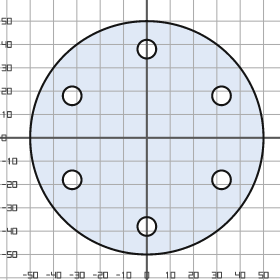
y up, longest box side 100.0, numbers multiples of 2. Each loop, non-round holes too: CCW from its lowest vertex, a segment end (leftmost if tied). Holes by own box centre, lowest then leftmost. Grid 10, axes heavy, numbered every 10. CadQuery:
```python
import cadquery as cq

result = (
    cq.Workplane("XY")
    .moveTo(0.0, 0.0)
    .circle(50.0)
    .moveTo(0.0, -38.0)
    .circle(4.0)
    .moveTo(-32.0, -18.0)
    .circle(4.0)
    .moveTo(32.0, -18.0)
    .circle(4.0)
    .moveTo(-32.0, 18.0)
    .circle(4.0)
    .moveTo(32.0, 18.0)
    .circle(4.0)
    .moveTo(0.0, 38.0)
    .circle(4.0)
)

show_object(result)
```